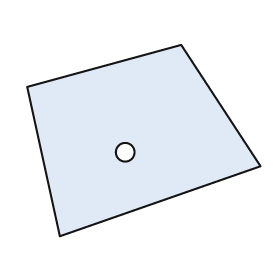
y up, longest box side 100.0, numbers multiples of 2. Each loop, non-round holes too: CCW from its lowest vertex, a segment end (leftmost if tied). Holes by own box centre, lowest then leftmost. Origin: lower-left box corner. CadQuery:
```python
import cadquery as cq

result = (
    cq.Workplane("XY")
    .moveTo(14.0, 0.0)
    .lineTo(100.0, 30.0)
    .lineTo(66.0, 82.0)
    .lineTo(0.0, 64.0)
    .close()
    .moveTo(42.0, 36.0)
    .circle(4.0)
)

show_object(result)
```